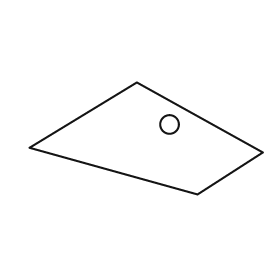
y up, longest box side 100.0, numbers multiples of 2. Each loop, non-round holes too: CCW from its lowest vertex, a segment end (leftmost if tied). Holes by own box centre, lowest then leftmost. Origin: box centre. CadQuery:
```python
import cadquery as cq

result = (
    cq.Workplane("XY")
    .moveTo(22.0, -24.0)
    .lineTo(50.0, -6.0)
    .lineTo(-4.0, 24.0)
    .lineTo(-50.0, -4.0)
    .close()
    .moveTo(10.0, 6.0)
    .circle(4.0)
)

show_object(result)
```